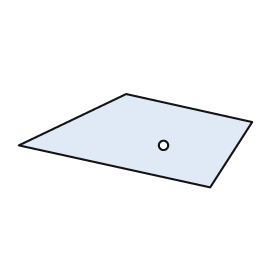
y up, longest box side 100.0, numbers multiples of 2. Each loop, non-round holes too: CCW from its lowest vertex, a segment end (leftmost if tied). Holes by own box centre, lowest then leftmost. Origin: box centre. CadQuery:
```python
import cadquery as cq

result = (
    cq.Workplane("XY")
    .moveTo(32.0, -20.0)
    .lineTo(50.0, 8.0)
    .lineTo(-4.0, 20.0)
    .lineTo(-50.0, -2.0)
    .close()
    .moveTo(12.0, -2.0)
    .circle(2.0)
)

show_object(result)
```